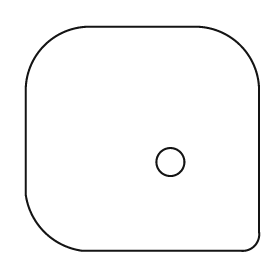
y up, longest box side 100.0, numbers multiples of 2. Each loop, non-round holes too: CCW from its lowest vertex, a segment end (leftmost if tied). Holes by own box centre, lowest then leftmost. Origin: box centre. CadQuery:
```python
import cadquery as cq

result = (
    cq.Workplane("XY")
    .moveTo(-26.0, -48.0)
    .lineTo(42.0, -48.0)
    .threePointArc((48.0, -46.0), (50.0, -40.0))
    .lineTo(50.0, 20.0)
    .threePointArc((42.0, 40.0), (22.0, 48.0))
    .lineTo(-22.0, 48.0)
    .threePointArc((-42.0, 40.0), (-50.0, 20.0))
    .lineTo(-50.0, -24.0)
    .threePointArc((-42.0, -40.0), (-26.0, -48.0))
    .close()
    .moveTo(12.0, -10.0)
    .circle(6.0)
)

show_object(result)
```